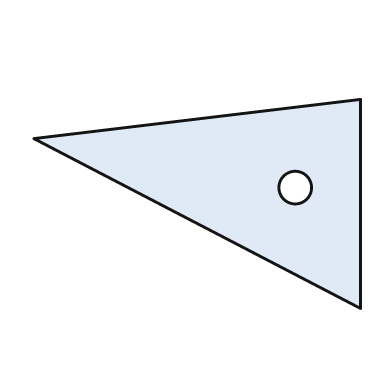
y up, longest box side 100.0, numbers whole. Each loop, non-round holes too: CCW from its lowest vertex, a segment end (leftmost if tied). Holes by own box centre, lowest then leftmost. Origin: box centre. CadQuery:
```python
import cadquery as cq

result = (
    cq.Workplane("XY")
    .moveTo(50.0, -32.0)
    .lineTo(50.0, 32.0)
    .lineTo(-50.0, 20.0)
    .close()
    .moveTo(30.0, 5.0)
    .circle(5.0)
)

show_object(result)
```